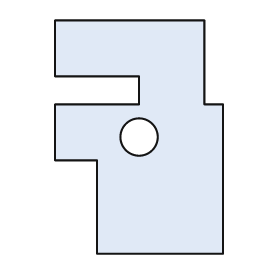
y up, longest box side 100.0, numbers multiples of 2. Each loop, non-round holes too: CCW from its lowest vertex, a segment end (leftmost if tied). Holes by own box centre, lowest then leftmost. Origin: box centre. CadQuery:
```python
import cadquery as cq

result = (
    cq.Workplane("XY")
    .moveTo(-18.0, -50.0)
    .lineTo(36.0, -50.0)
    .lineTo(36.0, 14.0)
    .lineTo(28.0, 14.0)
    .lineTo(28.0, 50.0)
    .lineTo(-36.0, 50.0)
    .lineTo(-36.0, 26.0)
    .lineTo(0.0, 26.0)
    .lineTo(0.0, 14.0)
    .lineTo(-36.0, 14.0)
    .lineTo(-36.0, -10.0)
    .lineTo(-18.0, -10.0)
    .close()
    .moveTo(0.0, 0.0)
    .circle(8.0)
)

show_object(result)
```